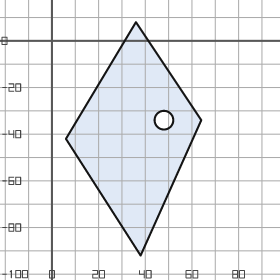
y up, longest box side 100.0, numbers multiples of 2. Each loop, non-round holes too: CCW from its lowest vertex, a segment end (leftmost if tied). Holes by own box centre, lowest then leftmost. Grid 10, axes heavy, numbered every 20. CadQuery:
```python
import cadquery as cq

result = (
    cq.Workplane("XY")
    .moveTo(38.0, -92.0)
    .lineTo(64.0, -34.0)
    .lineTo(36.0, 8.0)
    .lineTo(6.0, -42.0)
    .close()
    .moveTo(48.0, -34.0)
    .circle(4.0)
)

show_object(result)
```